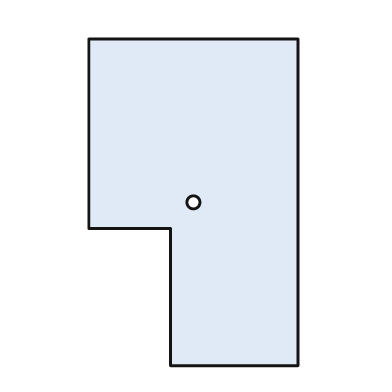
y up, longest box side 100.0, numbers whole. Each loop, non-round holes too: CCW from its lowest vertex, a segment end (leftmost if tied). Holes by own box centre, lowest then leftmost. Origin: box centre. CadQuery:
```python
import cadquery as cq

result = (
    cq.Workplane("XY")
    .moveTo(-7.0, -50.0)
    .lineTo(32.0, -50.0)
    .lineTo(32.0, 50.0)
    .lineTo(-32.0, 50.0)
    .lineTo(-32.0, -8.0)
    .lineTo(-7.0, -8.0)
    .close()
    .moveTo(0.0, 0.0)
    .circle(2.0)
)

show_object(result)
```